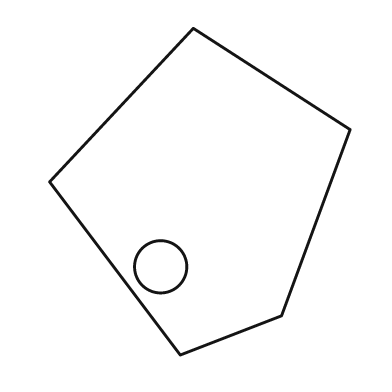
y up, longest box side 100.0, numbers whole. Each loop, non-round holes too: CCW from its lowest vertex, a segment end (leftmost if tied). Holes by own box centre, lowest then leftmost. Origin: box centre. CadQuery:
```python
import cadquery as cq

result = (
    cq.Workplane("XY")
    .moveTo(-6.0, -50.0)
    .lineTo(25.0, -38.0)
    .lineTo(46.0, 19.0)
    .lineTo(-2.0, 50.0)
    .lineTo(-46.0, 3.0)
    .close()
    .moveTo(-12.0, -23.0)
    .circle(8.0)
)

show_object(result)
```